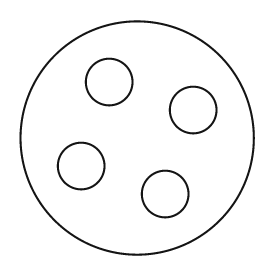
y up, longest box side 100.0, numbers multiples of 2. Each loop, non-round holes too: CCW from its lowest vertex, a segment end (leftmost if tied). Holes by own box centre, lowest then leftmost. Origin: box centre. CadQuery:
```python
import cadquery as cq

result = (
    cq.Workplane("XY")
    .moveTo(0.0, 0.0)
    .circle(50.0)
    .moveTo(12.0, -24.0)
    .circle(10.0)
    .moveTo(-24.0, -12.0)
    .circle(10.0)
    .moveTo(24.0, 12.0)
    .circle(10.0)
    .moveTo(-12.0, 24.0)
    .circle(10.0)
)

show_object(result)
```